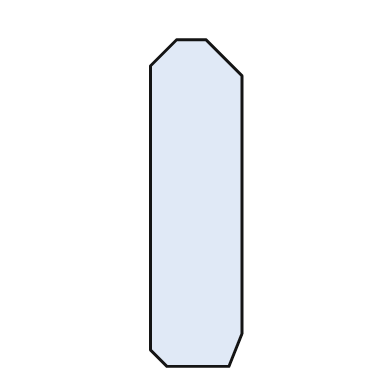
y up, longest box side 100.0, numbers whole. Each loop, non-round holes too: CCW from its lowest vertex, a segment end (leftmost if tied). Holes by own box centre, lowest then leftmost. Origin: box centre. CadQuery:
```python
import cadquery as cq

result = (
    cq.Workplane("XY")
    .moveTo(-9.0, -50.0)
    .lineTo(10.0, -50.0)
    .lineTo(14.0, -40.0)
    .lineTo(14.0, 39.0)
    .lineTo(3.0, 50.0)
    .lineTo(-6.0, 50.0)
    .lineTo(-14.0, 42.0)
    .lineTo(-14.0, -45.0)
    .close()
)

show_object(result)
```